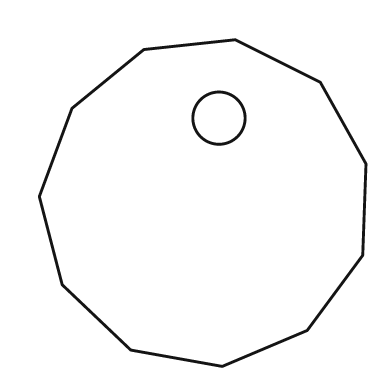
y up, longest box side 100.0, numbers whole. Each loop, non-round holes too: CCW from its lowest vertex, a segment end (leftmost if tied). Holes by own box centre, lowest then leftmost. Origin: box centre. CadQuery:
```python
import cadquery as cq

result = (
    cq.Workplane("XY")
    .moveTo(6.0, -50.0)
    .lineTo(32.0, -39.0)
    .lineTo(49.0, -16.0)
    .lineTo(50.0, 12.0)
    .lineTo(36.0, 37.0)
    .lineTo(10.0, 50.0)
    .lineTo(-18.0, 47.0)
    .lineTo(-40.0, 29.0)
    .lineTo(-50.0, 2.0)
    .lineTo(-43.0, -25.0)
    .lineTo(-22.0, -45.0)
    .close()
    .moveTo(5.0, 26.0)
    .circle(8.0)
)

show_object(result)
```